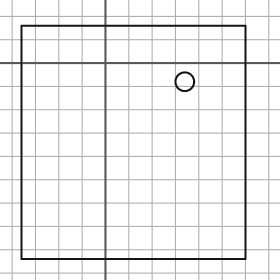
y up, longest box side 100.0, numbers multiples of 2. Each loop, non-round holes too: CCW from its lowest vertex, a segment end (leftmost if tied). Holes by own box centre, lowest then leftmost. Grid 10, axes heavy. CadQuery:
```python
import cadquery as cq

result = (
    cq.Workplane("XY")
    .moveTo(-36.0, -84.0)
    .lineTo(60.0, -84.0)
    .lineTo(60.0, 16.0)
    .lineTo(-36.0, 16.0)
    .close()
    .moveTo(34.0, -8.0)
    .circle(4.0)
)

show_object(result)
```